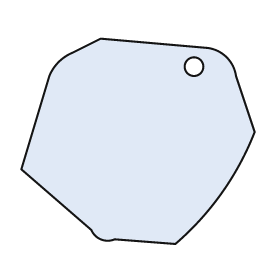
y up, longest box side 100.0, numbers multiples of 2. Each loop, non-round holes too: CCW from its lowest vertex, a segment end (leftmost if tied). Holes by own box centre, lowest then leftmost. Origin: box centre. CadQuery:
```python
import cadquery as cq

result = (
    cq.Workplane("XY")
    .moveTo(16.0, -44.0)
    .threePointArc((36.0, -22.0), (50.0, 4.0))
    .lineTo(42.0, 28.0)
    .threePointArc((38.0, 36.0), (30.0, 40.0))
    .lineTo(-16.0, 44.0)
    .lineTo(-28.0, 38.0)
    .threePointArc((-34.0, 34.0), (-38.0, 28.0))
    .lineTo(-50.0, -12.0)
    .lineTo(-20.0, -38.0)
    .threePointArc((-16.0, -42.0), (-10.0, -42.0))
    .close()
    .moveTo(24.0, 32.0)
    .circle(4.0)
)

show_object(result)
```